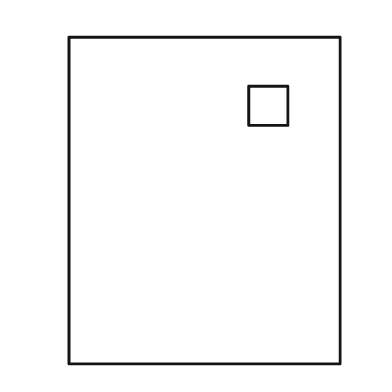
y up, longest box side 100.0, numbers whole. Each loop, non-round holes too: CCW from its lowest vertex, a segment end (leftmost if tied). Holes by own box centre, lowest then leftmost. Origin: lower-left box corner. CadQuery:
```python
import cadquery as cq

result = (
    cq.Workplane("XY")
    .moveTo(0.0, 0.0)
    .lineTo(83.0, 0.0)
    .lineTo(83.0, 100.0)
    .lineTo(0.0, 100.0)
    .close()
    .moveTo(55.0, 73.0)
    .lineTo(67.0, 73.0)
    .lineTo(67.0, 85.0)
    .lineTo(55.0, 85.0)
    .close()
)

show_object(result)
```